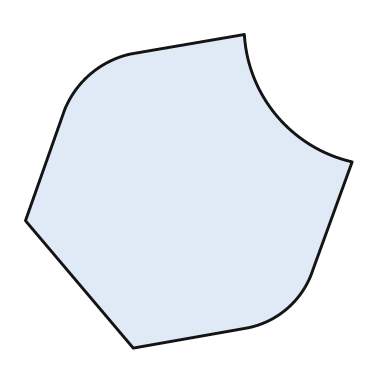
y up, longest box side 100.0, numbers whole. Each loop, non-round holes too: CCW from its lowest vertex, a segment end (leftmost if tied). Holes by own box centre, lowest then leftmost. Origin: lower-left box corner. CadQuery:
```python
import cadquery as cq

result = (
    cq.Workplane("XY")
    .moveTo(33.0, 0.0)
    .lineTo(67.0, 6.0)
    .threePointArc((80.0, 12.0), (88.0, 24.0))
    .lineTo(100.0, 57.0)
    .threePointArc((77.0, 71.0), (67.0, 96.0))
    .lineTo(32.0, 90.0)
    .threePointArc((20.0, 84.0), (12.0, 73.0))
    .lineTo(0.0, 39.0)
    .close()
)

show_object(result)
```